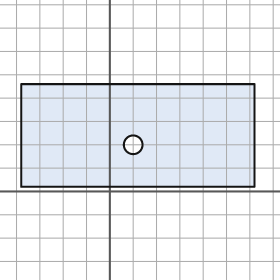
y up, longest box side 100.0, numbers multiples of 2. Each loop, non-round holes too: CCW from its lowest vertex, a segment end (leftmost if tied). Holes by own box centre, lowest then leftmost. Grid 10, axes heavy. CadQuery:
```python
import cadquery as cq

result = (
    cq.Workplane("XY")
    .moveTo(-38.0, 2.0)
    .lineTo(62.0, 2.0)
    .lineTo(62.0, 46.0)
    .lineTo(-38.0, 46.0)
    .close()
    .moveTo(10.0, 20.0)
    .circle(4.0)
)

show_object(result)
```